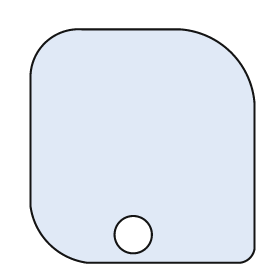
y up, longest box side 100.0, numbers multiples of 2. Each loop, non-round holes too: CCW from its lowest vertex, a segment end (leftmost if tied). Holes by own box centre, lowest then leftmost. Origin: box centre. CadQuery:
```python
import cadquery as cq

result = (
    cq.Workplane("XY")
    .moveTo(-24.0, -50.0)
    .lineTo(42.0, -50.0)
    .threePointArc((46.0, -48.0), (48.0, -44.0))
    .lineTo(48.0, 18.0)
    .threePointArc((38.0, 40.0), (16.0, 50.0))
    .lineTo(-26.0, 50.0)
    .threePointArc((-42.0, 44.0), (-48.0, 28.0))
    .lineTo(-48.0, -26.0)
    .threePointArc((-40.0, -42.0), (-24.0, -50.0))
    .close()
    .moveTo(-4.0, -38.0)
    .circle(8.0)
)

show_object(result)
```